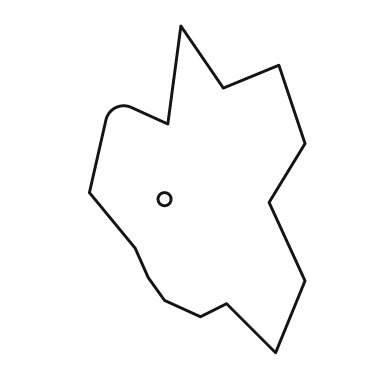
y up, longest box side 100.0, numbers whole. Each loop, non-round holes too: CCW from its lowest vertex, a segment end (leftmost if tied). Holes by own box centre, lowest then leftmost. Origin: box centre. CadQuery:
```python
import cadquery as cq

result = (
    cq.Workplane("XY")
    .moveTo(24.0, -50.0)
    .lineTo(33.0, -28.0)
    .lineTo(22.0, -4.0)
    .lineTo(33.0, 14.0)
    .lineTo(25.0, 38.0)
    .lineTo(8.0, 31.0)
    .lineTo(-5.0, 50.0)
    .lineTo(-9.0, 20.0)
    .lineTo(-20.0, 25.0)
    .threePointArc((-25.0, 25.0), (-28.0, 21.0))
    .lineTo(-33.0, -1.0)
    .lineTo(-19.0, -18.0)
    .lineTo(-15.0, -27.0)
    .lineTo(-10.0, -34.0)
    .lineTo(1.0, -39.0)
    .lineTo(9.0, -35.0)
    .close()
    .moveTo(-10.0, -3.0)
    .circle(2.0)
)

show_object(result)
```